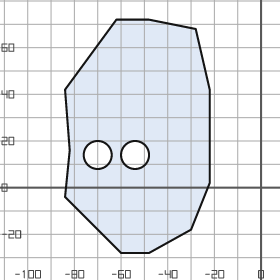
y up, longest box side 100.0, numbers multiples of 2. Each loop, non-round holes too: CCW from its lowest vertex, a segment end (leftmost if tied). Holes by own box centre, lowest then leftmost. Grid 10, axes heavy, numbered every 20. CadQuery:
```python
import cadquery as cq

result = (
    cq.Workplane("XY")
    .moveTo(-60.0, -28.0)
    .lineTo(-48.0, -28.0)
    .lineTo(-30.0, -18.0)
    .lineTo(-22.0, 2.0)
    .lineTo(-22.0, 42.0)
    .lineTo(-28.0, 68.0)
    .lineTo(-48.0, 72.0)
    .lineTo(-62.0, 72.0)
    .lineTo(-84.0, 42.0)
    .lineTo(-82.0, 16.0)
    .lineTo(-84.0, -4.0)
    .close()
    .moveTo(-70.0, 14.0)
    .circle(6.0)
    .moveTo(-54.0, 14.0)
    .circle(6.0)
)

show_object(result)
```